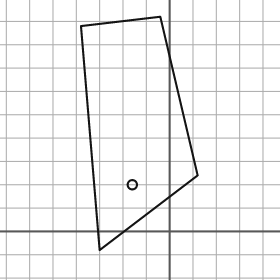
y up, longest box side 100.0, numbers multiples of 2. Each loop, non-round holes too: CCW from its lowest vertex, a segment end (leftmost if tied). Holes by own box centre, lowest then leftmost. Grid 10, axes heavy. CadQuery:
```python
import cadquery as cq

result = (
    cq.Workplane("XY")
    .moveTo(-30.0, -8.0)
    .lineTo(12.0, 24.0)
    .lineTo(-4.0, 92.0)
    .lineTo(-38.0, 88.0)
    .close()
    .moveTo(-16.0, 20.0)
    .circle(2.0)
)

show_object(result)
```